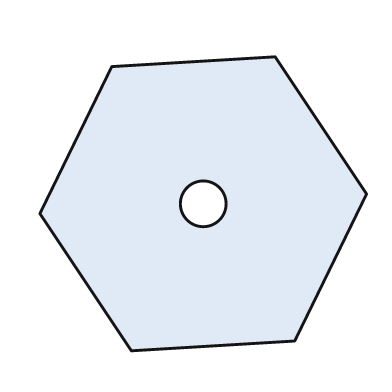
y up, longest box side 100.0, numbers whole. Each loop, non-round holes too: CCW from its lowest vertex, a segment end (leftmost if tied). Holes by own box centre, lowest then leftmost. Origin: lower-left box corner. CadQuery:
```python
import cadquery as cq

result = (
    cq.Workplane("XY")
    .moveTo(28.0, 0.0)
    .lineTo(78.0, 3.0)
    .lineTo(100.0, 48.0)
    .lineTo(72.0, 90.0)
    .lineTo(22.0, 87.0)
    .lineTo(0.0, 42.0)
    .close()
    .moveTo(50.0, 45.0)
    .circle(7.0)
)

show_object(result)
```